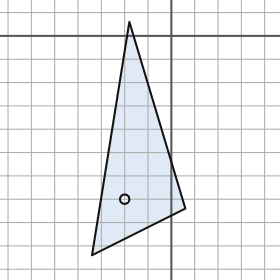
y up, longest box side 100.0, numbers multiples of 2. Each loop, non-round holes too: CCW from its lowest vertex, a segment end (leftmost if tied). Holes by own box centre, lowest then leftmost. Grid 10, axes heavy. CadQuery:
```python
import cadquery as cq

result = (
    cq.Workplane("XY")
    .moveTo(-34.0, -94.0)
    .lineTo(6.0, -74.0)
    .lineTo(-18.0, 6.0)
    .close()
    .moveTo(-20.0, -70.0)
    .circle(2.0)
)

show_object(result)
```